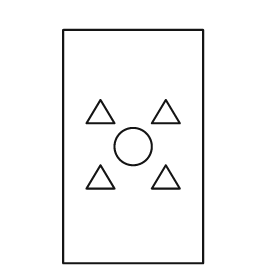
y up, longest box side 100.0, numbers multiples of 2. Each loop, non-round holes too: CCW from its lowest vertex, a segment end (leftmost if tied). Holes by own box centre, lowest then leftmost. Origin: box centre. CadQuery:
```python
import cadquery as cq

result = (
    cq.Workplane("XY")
    .moveTo(-30.0, -50.0)
    .lineTo(30.0, -50.0)
    .lineTo(30.0, 50.0)
    .lineTo(-30.0, 50.0)
    .close()
    .moveTo(-20.0, -18.0)
    .lineTo(-8.0, -18.0)
    .lineTo(-14.0, -8.0)
    .close()
    .moveTo(8.0, -18.0)
    .lineTo(20.0, -18.0)
    .lineTo(14.0, -8.0)
    .close()
    .moveTo(0.0, 0.0)
    .circle(8.0)
    .moveTo(-20.0, 10.0)
    .lineTo(-8.0, 10.0)
    .lineTo(-14.0, 20.0)
    .close()
    .moveTo(8.0, 10.0)
    .lineTo(20.0, 10.0)
    .lineTo(14.0, 20.0)
    .close()
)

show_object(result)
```